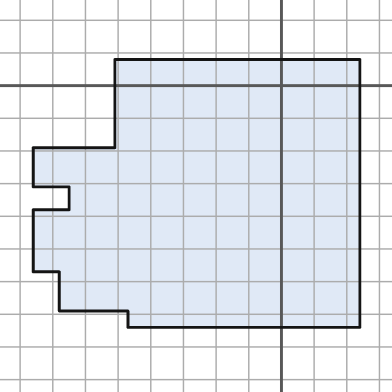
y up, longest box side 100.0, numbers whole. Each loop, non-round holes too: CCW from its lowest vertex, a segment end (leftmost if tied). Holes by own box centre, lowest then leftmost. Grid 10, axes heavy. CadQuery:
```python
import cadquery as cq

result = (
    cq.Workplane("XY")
    .moveTo(-47.0, -74.0)
    .lineTo(24.0, -74.0)
    .lineTo(24.0, 8.0)
    .lineTo(-51.0, 8.0)
    .lineTo(-51.0, -19.0)
    .lineTo(-76.0, -19.0)
    .lineTo(-76.0, -31.0)
    .lineTo(-65.0, -31.0)
    .lineTo(-65.0, -38.0)
    .lineTo(-76.0, -38.0)
    .lineTo(-76.0, -57.0)
    .lineTo(-68.0, -57.0)
    .lineTo(-68.0, -69.0)
    .lineTo(-47.0, -69.0)
    .close()
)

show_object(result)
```